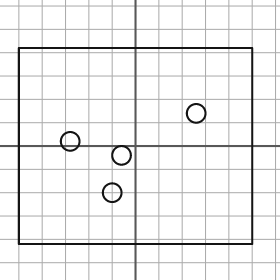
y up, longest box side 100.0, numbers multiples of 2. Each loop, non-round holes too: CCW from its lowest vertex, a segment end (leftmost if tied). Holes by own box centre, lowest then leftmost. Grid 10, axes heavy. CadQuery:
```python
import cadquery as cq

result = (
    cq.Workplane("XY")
    .moveTo(-50.0, -42.0)
    .lineTo(50.0, -42.0)
    .lineTo(50.0, 42.0)
    .lineTo(-50.0, 42.0)
    .close()
    .moveTo(-10.0, -20.0)
    .circle(4.0)
    .moveTo(-6.0, -4.0)
    .circle(4.0)
    .moveTo(-28.0, 2.0)
    .circle(4.0)
    .moveTo(26.0, 14.0)
    .circle(4.0)
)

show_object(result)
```